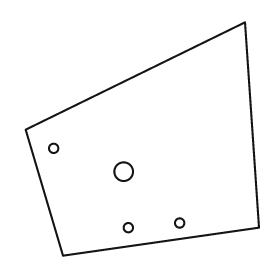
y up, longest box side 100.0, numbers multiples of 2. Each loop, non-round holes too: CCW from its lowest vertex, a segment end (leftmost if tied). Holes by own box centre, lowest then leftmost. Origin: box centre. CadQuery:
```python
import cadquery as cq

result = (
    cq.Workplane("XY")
    .moveTo(-34.0, -50.0)
    .lineTo(50.0, -38.0)
    .lineTo(44.0, 50.0)
    .lineTo(-50.0, 4.0)
    .close()
    .moveTo(-6.0, -38.0)
    .circle(2.0)
    .moveTo(16.0, -36.0)
    .circle(2.0)
    .moveTo(-8.0, -14.0)
    .circle(4.0)
    .moveTo(-38.0, -4.0)
    .circle(2.0)
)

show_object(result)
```